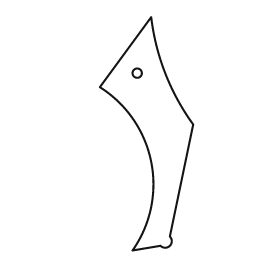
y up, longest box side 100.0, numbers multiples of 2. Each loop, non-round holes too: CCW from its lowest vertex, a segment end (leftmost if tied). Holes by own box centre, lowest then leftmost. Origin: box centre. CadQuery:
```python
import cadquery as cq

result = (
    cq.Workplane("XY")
    .moveTo(-6.0, -50.0)
    .lineTo(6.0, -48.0)
    .threePointArc((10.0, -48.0), (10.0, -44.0))
    .lineTo(20.0, 4.0)
    .threePointArc((8.0, 26.0), (2.0, 50.0))
    .lineTo(-20.0, 20.0)
    .threePointArc((2.0, -12.0), (-6.0, -50.0))
    .close()
    .moveTo(-4.0, 26.0)
    .circle(2.0)
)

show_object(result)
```